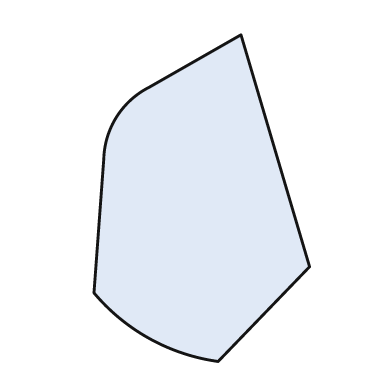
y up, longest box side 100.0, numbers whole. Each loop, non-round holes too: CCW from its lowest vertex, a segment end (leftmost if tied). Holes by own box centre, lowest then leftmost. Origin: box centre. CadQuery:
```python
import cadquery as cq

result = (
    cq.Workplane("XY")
    .moveTo(5.0, -50.0)
    .lineTo(33.0, -21.0)
    .lineTo(12.0, 50.0)
    .lineTo(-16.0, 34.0)
    .threePointArc((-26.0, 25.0), (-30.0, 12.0))
    .lineTo(-33.0, -29.0)
    .threePointArc((-16.0, -43.0), (5.0, -50.0))
    .close()
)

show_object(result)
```